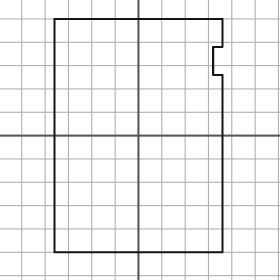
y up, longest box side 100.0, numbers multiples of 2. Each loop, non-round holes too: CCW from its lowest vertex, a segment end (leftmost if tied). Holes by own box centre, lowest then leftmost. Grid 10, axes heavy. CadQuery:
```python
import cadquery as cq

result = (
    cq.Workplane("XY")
    .moveTo(-36.0, -50.0)
    .lineTo(36.0, -50.0)
    .lineTo(36.0, 26.0)
    .lineTo(32.0, 26.0)
    .lineTo(32.0, 38.0)
    .lineTo(36.0, 38.0)
    .lineTo(36.0, 50.0)
    .lineTo(-36.0, 50.0)
    .close()
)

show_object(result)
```